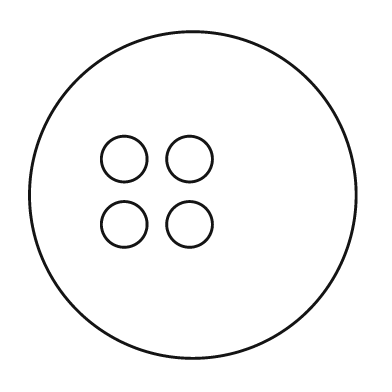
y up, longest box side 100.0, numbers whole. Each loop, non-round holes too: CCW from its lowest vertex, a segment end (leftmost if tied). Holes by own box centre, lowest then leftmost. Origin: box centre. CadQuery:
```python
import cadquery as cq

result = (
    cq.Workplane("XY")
    .moveTo(0.0, 0.0)
    .circle(50.0)
    .moveTo(-21.0, -9.0)
    .circle(7.0)
    .moveTo(-1.0, -9.0)
    .circle(7.0)
    .moveTo(-21.0, 11.0)
    .circle(7.0)
    .moveTo(-1.0, 11.0)
    .circle(7.0)
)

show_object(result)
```